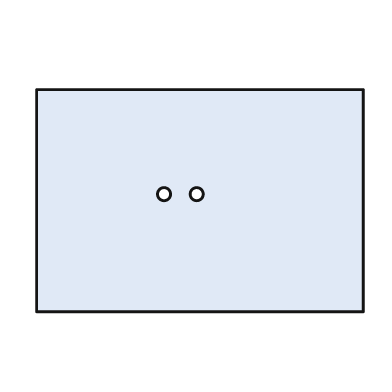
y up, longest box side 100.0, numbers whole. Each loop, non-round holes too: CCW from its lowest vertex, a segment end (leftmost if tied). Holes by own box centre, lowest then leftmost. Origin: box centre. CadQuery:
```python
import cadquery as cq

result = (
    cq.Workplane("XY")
    .moveTo(-50.0, -34.0)
    .lineTo(50.0, -34.0)
    .lineTo(50.0, 34.0)
    .lineTo(-50.0, 34.0)
    .close()
    .moveTo(-11.0, 2.0)
    .circle(2.0)
    .moveTo(-1.0, 2.0)
    .circle(2.0)
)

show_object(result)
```